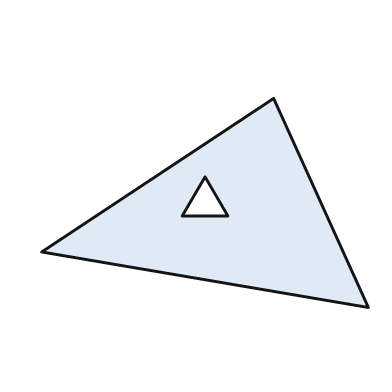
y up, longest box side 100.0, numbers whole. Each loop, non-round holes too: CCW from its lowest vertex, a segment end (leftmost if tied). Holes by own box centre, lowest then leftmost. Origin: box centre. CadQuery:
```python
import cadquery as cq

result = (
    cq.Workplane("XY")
    .moveTo(50.0, -32.0)
    .lineTo(21.0, 32.0)
    .lineTo(-50.0, -15.0)
    .close()
    .moveTo(-7.0, -4.0)
    .lineTo(7.0, -4.0)
    .lineTo(0.0, 8.0)
    .close()
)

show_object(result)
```